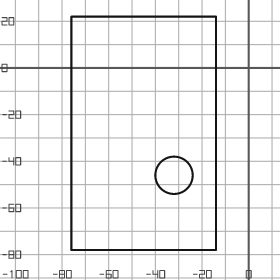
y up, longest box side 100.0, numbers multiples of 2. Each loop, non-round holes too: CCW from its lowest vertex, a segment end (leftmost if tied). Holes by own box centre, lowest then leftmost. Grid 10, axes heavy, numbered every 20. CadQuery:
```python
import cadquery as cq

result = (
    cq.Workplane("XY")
    .moveTo(-76.0, -78.0)
    .lineTo(-14.0, -78.0)
    .lineTo(-14.0, 22.0)
    .lineTo(-76.0, 22.0)
    .close()
    .moveTo(-32.0, -46.0)
    .circle(8.0)
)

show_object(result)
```